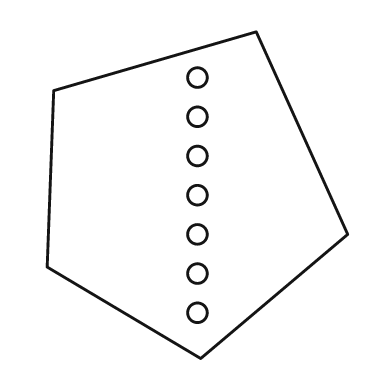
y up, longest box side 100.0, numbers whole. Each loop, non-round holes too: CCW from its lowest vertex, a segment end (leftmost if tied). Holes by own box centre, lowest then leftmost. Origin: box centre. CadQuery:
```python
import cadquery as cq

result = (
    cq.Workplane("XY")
    .moveTo(1.0, -50.0)
    .lineTo(46.0, -12.0)
    .lineTo(18.0, 50.0)
    .lineTo(-44.0, 32.0)
    .lineTo(-46.0, -22.0)
    .close()
    .moveTo(0.0, -36.0)
    .circle(3.0)
    .moveTo(0.0, -24.0)
    .circle(3.0)
    .moveTo(0.0, -12.0)
    .circle(3.0)
    .moveTo(0.0, 0.0)
    .circle(3.0)
    .moveTo(0.0, 12.0)
    .circle(3.0)
    .moveTo(0.0, 24.0)
    .circle(3.0)
    .moveTo(0.0, 36.0)
    .circle(3.0)
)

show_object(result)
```